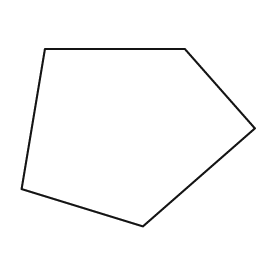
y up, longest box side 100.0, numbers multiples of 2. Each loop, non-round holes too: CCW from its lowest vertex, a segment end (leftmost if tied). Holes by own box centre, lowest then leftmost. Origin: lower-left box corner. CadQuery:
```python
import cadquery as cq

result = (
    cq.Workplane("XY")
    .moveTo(52.0, 0.0)
    .lineTo(100.0, 42.0)
    .lineTo(70.0, 76.0)
    .lineTo(10.0, 76.0)
    .lineTo(0.0, 16.0)
    .close()
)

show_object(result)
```